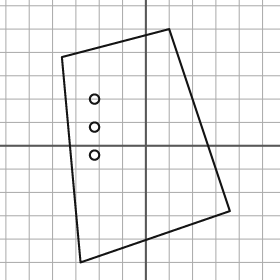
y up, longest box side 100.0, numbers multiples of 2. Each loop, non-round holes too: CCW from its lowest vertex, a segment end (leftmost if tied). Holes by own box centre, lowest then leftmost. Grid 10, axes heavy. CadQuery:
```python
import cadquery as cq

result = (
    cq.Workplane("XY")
    .moveTo(-28.0, -50.0)
    .lineTo(36.0, -28.0)
    .lineTo(10.0, 50.0)
    .lineTo(-36.0, 38.0)
    .close()
    .moveTo(-22.0, -4.0)
    .circle(2.0)
    .moveTo(-22.0, 8.0)
    .circle(2.0)
    .moveTo(-22.0, 20.0)
    .circle(2.0)
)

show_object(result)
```